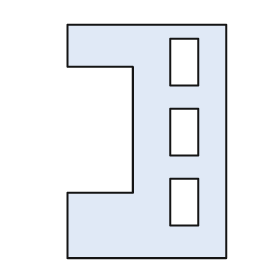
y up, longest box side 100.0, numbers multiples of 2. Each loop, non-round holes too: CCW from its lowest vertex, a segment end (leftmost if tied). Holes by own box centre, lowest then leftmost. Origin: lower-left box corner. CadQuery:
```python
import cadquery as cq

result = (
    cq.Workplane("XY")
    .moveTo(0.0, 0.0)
    .lineTo(68.0, 0.0)
    .lineTo(68.0, 100.0)
    .lineTo(0.0, 100.0)
    .lineTo(0.0, 82.0)
    .lineTo(28.0, 82.0)
    .lineTo(28.0, 28.0)
    .lineTo(0.0, 28.0)
    .close()
    .moveTo(44.0, 14.0)
    .lineTo(56.0, 14.0)
    .lineTo(56.0, 34.0)
    .lineTo(44.0, 34.0)
    .close()
    .moveTo(44.0, 44.0)
    .lineTo(56.0, 44.0)
    .lineTo(56.0, 64.0)
    .lineTo(44.0, 64.0)
    .close()
    .moveTo(44.0, 74.0)
    .lineTo(56.0, 74.0)
    .lineTo(56.0, 94.0)
    .lineTo(44.0, 94.0)
    .close()
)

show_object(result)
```